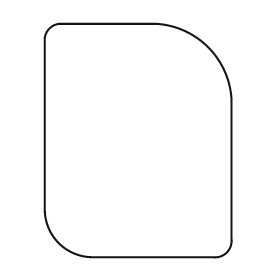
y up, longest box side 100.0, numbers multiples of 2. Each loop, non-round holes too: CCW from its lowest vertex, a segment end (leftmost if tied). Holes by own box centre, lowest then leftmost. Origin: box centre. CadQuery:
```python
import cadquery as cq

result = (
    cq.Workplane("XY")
    .moveTo(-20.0, -50.0)
    .lineTo(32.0, -50.0)
    .threePointArc((38.0, -48.0), (40.0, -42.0))
    .lineTo(40.0, 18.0)
    .threePointArc((30.0, 40.0), (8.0, 50.0))
    .lineTo(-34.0, 50.0)
    .threePointArc((-38.0, 48.0), (-40.0, 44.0))
    .lineTo(-40.0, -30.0)
    .threePointArc((-34.0, -44.0), (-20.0, -50.0))
    .close()
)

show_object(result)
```